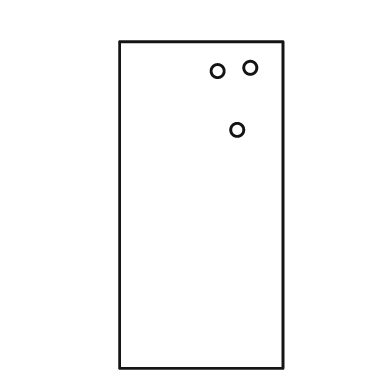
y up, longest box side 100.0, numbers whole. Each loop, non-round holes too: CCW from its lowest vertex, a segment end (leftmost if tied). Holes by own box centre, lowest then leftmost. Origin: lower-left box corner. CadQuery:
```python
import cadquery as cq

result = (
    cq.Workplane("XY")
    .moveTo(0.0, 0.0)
    .lineTo(50.0, 0.0)
    .lineTo(50.0, 100.0)
    .lineTo(0.0, 100.0)
    .close()
    .moveTo(36.0, 73.0)
    .circle(2.0)
    .moveTo(30.0, 91.0)
    .circle(2.0)
    .moveTo(40.0, 92.0)
    .circle(2.0)
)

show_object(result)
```